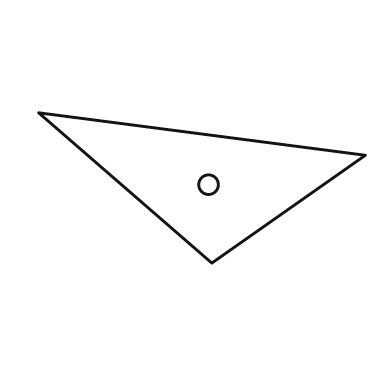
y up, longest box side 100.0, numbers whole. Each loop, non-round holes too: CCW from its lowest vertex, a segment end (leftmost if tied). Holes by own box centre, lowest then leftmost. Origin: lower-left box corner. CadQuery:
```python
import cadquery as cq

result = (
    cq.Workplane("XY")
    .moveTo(53.0, 0.0)
    .lineTo(100.0, 33.0)
    .lineTo(0.0, 46.0)
    .close()
    .moveTo(52.0, 24.0)
    .circle(3.0)
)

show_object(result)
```